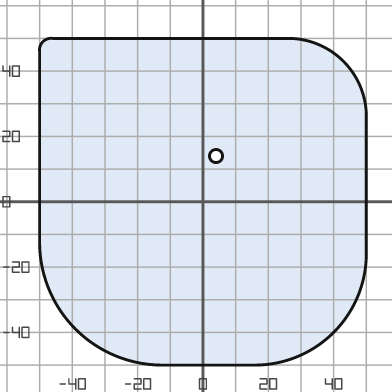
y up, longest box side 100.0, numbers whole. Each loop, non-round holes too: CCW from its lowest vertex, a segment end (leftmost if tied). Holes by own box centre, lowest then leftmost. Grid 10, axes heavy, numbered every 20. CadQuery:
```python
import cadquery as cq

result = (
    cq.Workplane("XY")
    .moveTo(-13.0, -50.0)
    .lineTo(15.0, -50.0)
    .threePointArc((40.0, -40.0), (50.0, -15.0))
    .lineTo(50.0, 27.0)
    .threePointArc((43.0, 43.0), (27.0, 50.0))
    .lineTo(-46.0, 50.0)
    .threePointArc((-49.0, 49.0), (-50.0, 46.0))
    .lineTo(-50.0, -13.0)
    .threePointArc((-39.0, -39.0), (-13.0, -50.0))
    .close()
    .moveTo(4.0, 14.0)
    .circle(2.0)
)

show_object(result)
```